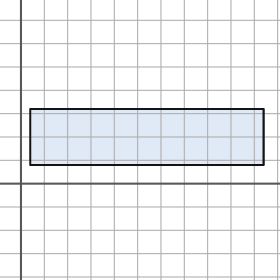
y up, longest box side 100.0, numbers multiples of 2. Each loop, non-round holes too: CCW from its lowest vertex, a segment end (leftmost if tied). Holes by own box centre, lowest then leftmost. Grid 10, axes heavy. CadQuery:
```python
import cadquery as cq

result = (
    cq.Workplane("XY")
    .moveTo(4.0, 8.0)
    .lineTo(104.0, 8.0)
    .lineTo(104.0, 32.0)
    .lineTo(4.0, 32.0)
    .close()
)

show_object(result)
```